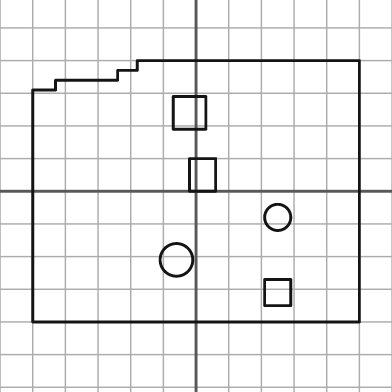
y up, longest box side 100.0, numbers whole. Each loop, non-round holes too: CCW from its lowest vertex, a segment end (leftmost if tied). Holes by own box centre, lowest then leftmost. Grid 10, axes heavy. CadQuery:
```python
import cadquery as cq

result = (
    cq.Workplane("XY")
    .moveTo(-50.0, -40.0)
    .lineTo(50.0, -40.0)
    .lineTo(50.0, 40.0)
    .lineTo(-18.0, 40.0)
    .lineTo(-18.0, 37.0)
    .lineTo(-24.0, 37.0)
    .lineTo(-24.0, 34.0)
    .lineTo(-43.0, 34.0)
    .lineTo(-43.0, 31.0)
    .lineTo(-50.0, 31.0)
    .close()
    .moveTo(21.0, -35.0)
    .lineTo(29.0, -35.0)
    .lineTo(29.0, -27.0)
    .lineTo(21.0, -27.0)
    .close()
    .moveTo(-6.0, -21.0)
    .circle(5.0)
    .moveTo(25.0, -8.0)
    .circle(4.0)
    .moveTo(-2.0, 0.0)
    .lineTo(6.0, 0.0)
    .lineTo(6.0, 10.0)
    .lineTo(-2.0, 10.0)
    .close()
    .moveTo(-7.0, 19.0)
    .lineTo(3.0, 19.0)
    .lineTo(3.0, 29.0)
    .lineTo(-7.0, 29.0)
    .close()
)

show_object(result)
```